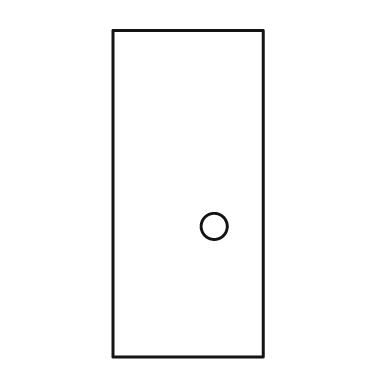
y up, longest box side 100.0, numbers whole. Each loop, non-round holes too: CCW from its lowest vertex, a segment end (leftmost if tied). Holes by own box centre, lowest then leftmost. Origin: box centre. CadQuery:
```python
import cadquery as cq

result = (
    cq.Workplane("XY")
    .moveTo(-23.0, -50.0)
    .lineTo(23.0, -50.0)
    .lineTo(23.0, 50.0)
    .lineTo(-23.0, 50.0)
    .close()
    .moveTo(8.0, -10.0)
    .circle(4.0)
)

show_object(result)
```